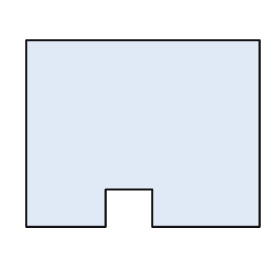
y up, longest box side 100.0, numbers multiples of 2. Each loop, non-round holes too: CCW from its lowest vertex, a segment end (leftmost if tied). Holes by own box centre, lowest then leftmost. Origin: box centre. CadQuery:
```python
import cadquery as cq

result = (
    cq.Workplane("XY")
    .moveTo(-50.0, -40.0)
    .lineTo(-16.0, -40.0)
    .lineTo(-16.0, -24.0)
    .lineTo(4.0, -24.0)
    .lineTo(4.0, -40.0)
    .lineTo(50.0, -40.0)
    .lineTo(50.0, 40.0)
    .lineTo(-50.0, 40.0)
    .close()
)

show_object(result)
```